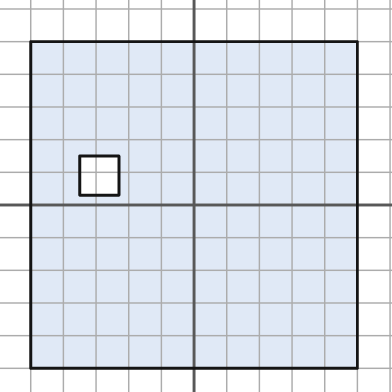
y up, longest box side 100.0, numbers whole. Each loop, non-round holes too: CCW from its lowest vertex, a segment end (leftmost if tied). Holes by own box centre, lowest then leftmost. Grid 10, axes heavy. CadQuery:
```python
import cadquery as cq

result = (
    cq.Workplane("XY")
    .moveTo(-50.0, -50.0)
    .lineTo(50.0, -50.0)
    .lineTo(50.0, 50.0)
    .lineTo(-50.0, 50.0)
    .close()
    .moveTo(-35.0, 3.0)
    .lineTo(-23.0, 3.0)
    .lineTo(-23.0, 15.0)
    .lineTo(-35.0, 15.0)
    .close()
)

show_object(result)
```